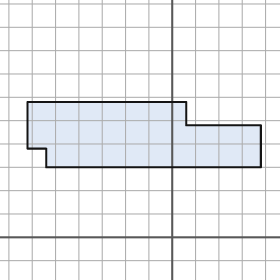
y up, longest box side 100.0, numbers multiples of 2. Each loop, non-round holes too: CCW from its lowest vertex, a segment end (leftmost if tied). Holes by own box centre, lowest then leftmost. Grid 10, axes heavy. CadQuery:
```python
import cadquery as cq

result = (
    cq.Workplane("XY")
    .moveTo(-54.0, 30.0)
    .lineTo(38.0, 30.0)
    .lineTo(38.0, 48.0)
    .lineTo(6.0, 48.0)
    .lineTo(6.0, 58.0)
    .lineTo(-62.0, 58.0)
    .lineTo(-62.0, 38.0)
    .lineTo(-54.0, 38.0)
    .close()
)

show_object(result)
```